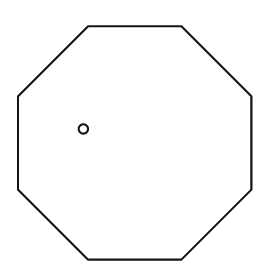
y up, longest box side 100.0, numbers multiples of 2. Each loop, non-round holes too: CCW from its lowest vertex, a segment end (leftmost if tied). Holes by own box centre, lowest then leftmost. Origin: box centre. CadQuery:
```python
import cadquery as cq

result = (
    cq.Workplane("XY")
    .moveTo(-20.0, -50.0)
    .lineTo(20.0, -50.0)
    .lineTo(50.0, -20.0)
    .lineTo(50.0, 20.0)
    .lineTo(20.0, 50.0)
    .lineTo(-20.0, 50.0)
    .lineTo(-50.0, 20.0)
    .lineTo(-50.0, -20.0)
    .close()
    .moveTo(-22.0, 6.0)
    .circle(2.0)
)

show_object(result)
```